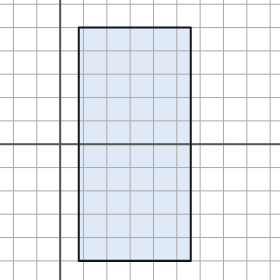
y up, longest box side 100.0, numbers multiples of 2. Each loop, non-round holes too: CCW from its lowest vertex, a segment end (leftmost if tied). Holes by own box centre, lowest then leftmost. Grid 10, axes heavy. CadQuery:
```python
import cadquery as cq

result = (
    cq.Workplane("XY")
    .moveTo(8.0, -50.0)
    .lineTo(56.0, -50.0)
    .lineTo(56.0, 50.0)
    .lineTo(8.0, 50.0)
    .close()
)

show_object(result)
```